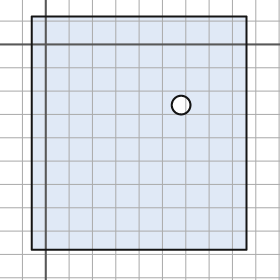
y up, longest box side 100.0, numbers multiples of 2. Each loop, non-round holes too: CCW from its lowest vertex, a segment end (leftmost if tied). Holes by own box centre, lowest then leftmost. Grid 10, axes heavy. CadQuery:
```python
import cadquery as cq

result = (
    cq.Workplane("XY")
    .moveTo(-6.0, -88.0)
    .lineTo(86.0, -88.0)
    .lineTo(86.0, 12.0)
    .lineTo(-6.0, 12.0)
    .close()
    .moveTo(58.0, -26.0)
    .circle(4.0)
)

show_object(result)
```